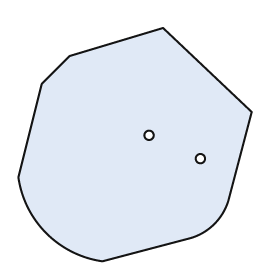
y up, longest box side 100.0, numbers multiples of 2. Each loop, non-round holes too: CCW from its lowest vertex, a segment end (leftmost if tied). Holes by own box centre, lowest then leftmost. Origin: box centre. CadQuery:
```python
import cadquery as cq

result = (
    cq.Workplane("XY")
    .moveTo(-14.0, -50.0)
    .lineTo(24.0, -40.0)
    .threePointArc((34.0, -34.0), (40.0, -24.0))
    .lineTo(50.0, 14.0)
    .lineTo(12.0, 50.0)
    .lineTo(-28.0, 38.0)
    .lineTo(-40.0, 26.0)
    .lineTo(-50.0, -14.0)
    .threePointArc((-38.0, -38.0), (-14.0, -50.0))
    .close()
    .moveTo(28.0, -6.0)
    .circle(2.0)
    .moveTo(6.0, 4.0)
    .circle(2.0)
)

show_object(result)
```